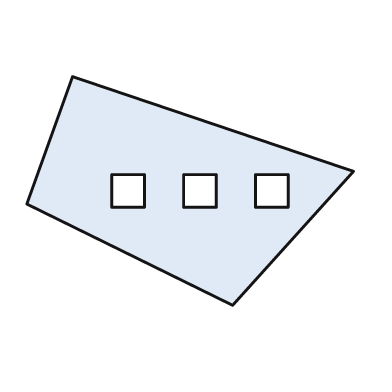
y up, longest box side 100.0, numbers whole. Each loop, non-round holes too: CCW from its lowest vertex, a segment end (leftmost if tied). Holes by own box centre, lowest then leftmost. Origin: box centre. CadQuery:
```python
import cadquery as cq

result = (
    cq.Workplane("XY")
    .moveTo(13.0, -35.0)
    .lineTo(50.0, 6.0)
    .lineTo(-36.0, 35.0)
    .lineTo(-50.0, -4.0)
    .close()
    .moveTo(-24.0, -5.0)
    .lineTo(-14.0, -5.0)
    .lineTo(-14.0, 5.0)
    .lineTo(-24.0, 5.0)
    .close()
    .moveTo(-2.0, -5.0)
    .lineTo(8.0, -5.0)
    .lineTo(8.0, 5.0)
    .lineTo(-2.0, 5.0)
    .close()
    .moveTo(20.0, -5.0)
    .lineTo(30.0, -5.0)
    .lineTo(30.0, 5.0)
    .lineTo(20.0, 5.0)
    .close()
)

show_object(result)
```